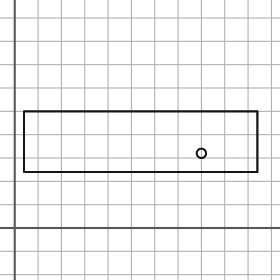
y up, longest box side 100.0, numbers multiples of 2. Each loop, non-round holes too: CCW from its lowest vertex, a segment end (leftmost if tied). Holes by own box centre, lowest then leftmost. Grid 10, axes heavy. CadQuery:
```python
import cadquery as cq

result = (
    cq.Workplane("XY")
    .moveTo(4.0, 24.0)
    .lineTo(104.0, 24.0)
    .lineTo(104.0, 50.0)
    .lineTo(4.0, 50.0)
    .close()
    .moveTo(80.0, 32.0)
    .circle(2.0)
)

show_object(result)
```